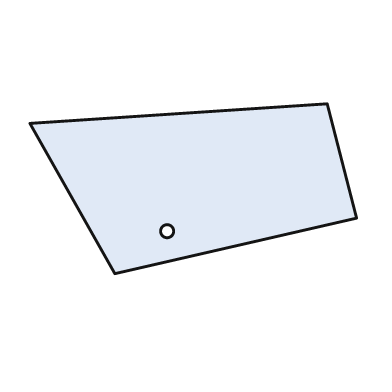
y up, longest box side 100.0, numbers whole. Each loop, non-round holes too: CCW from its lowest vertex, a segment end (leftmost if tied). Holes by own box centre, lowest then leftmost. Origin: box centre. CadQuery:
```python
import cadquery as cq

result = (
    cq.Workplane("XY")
    .moveTo(-24.0, -26.0)
    .lineTo(50.0, -9.0)
    .lineTo(41.0, 26.0)
    .lineTo(-50.0, 20.0)
    .close()
    .moveTo(-8.0, -13.0)
    .circle(2.0)
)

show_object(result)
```